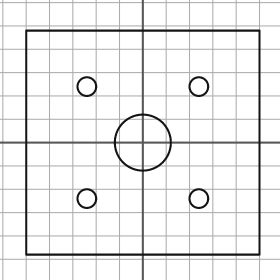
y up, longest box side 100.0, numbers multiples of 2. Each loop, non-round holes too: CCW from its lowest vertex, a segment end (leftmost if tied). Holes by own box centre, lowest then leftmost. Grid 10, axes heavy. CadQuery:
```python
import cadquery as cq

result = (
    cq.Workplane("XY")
    .moveTo(-50.0, -48.0)
    .lineTo(50.0, -48.0)
    .lineTo(50.0, 48.0)
    .lineTo(-50.0, 48.0)
    .close()
    .moveTo(-24.0, -24.0)
    .circle(4.0)
    .moveTo(24.0, -24.0)
    .circle(4.0)
    .moveTo(0.0, 0.0)
    .circle(12.0)
    .moveTo(-24.0, 24.0)
    .circle(4.0)
    .moveTo(24.0, 24.0)
    .circle(4.0)
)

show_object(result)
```